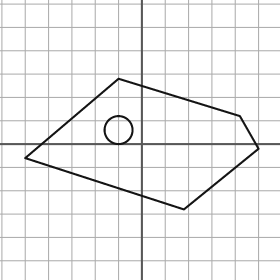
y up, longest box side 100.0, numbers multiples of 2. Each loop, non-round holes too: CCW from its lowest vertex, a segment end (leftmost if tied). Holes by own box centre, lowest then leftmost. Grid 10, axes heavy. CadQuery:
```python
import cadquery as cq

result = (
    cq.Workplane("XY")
    .moveTo(18.0, -28.0)
    .lineTo(50.0, -2.0)
    .lineTo(42.0, 12.0)
    .lineTo(-10.0, 28.0)
    .lineTo(-50.0, -6.0)
    .close()
    .moveTo(-10.0, 6.0)
    .circle(6.0)
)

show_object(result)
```